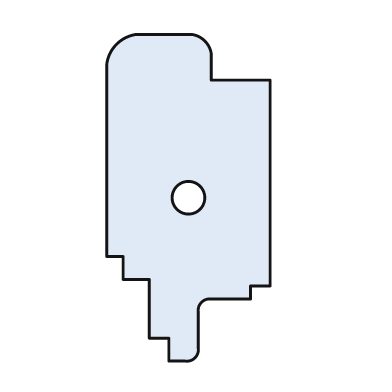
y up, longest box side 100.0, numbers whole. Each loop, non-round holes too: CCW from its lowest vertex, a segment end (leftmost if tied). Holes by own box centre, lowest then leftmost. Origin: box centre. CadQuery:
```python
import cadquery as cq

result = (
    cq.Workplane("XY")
    .moveTo(-6.0, -50.0)
    .lineTo(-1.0, -50.0)
    .threePointArc((2.0, -49.0), (3.0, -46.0))
    .lineTo(3.0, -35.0)
    .threePointArc((4.0, -32.0), (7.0, -31.0))
    .lineTo(19.0, -31.0)
    .lineTo(19.0, -27.0)
    .lineTo(25.0, -27.0)
    .lineTo(25.0, 36.0)
    .lineTo(7.0, 36.0)
    .lineTo(7.0, 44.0)
    .threePointArc((5.0, 48.0), (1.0, 50.0))
    .lineTo(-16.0, 50.0)
    .threePointArc((-22.0, 47.0), (-25.0, 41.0))
    .lineTo(-25.0, -18.0)
    .lineTo(-20.0, -18.0)
    .lineTo(-20.0, -25.0)
    .lineTo(-12.0, -25.0)
    .lineTo(-12.0, -43.0)
    .lineTo(-6.0, -43.0)
    .close()
    .moveTo(0.0, 0.0)
    .circle(5.0)
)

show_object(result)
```